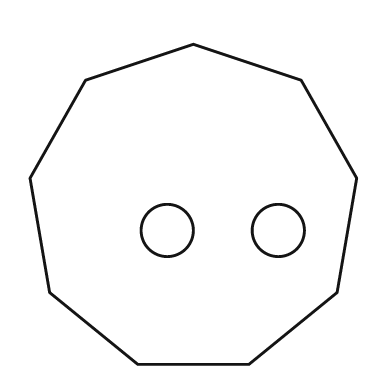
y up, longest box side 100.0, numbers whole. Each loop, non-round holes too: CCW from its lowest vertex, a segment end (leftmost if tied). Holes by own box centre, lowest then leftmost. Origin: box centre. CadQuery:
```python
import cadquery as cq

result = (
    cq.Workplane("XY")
    .moveTo(-17.0, -49.0)
    .lineTo(17.0, -49.0)
    .lineTo(44.0, -27.0)
    .lineTo(50.0, 8.0)
    .lineTo(33.0, 38.0)
    .lineTo(0.0, 49.0)
    .lineTo(-33.0, 38.0)
    .lineTo(-50.0, 8.0)
    .lineTo(-44.0, -27.0)
    .close()
    .moveTo(-8.0, -8.0)
    .circle(8.0)
    .moveTo(26.0, -8.0)
    .circle(8.0)
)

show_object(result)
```